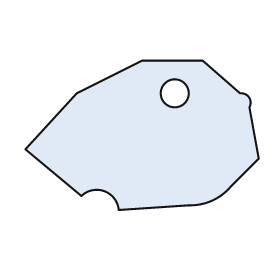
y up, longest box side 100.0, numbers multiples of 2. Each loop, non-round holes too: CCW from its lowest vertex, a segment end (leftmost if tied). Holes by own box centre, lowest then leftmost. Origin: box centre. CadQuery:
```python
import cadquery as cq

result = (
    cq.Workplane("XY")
    .moveTo(-10.0, -32.0)
    .lineTo(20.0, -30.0)
    .threePointArc((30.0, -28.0), (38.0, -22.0))
    .lineTo(50.0, -10.0)
    .lineTo(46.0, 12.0)
    .threePointArc((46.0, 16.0), (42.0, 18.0))
    .lineTo(26.0, 32.0)
    .lineTo(0.0, 32.0)
    .lineTo(-28.0, 18.0)
    .lineTo(-50.0, -6.0)
    .lineTo(-26.0, -26.0)
    .threePointArc((-16.0, -24.0), (-10.0, -32.0))
    .close()
    .moveTo(14.0, 18.0)
    .circle(6.0)
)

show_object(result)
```